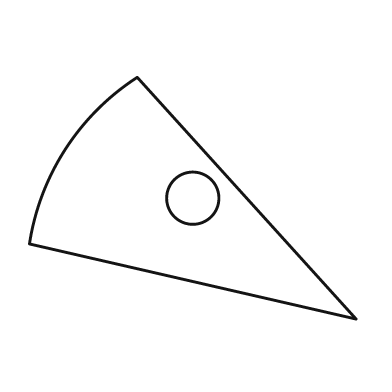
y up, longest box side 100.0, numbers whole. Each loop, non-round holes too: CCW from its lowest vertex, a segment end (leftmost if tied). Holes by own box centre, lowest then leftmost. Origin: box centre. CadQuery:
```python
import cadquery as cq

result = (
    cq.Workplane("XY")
    .moveTo(50.0, -37.0)
    .lineTo(-17.0, 37.0)
    .threePointArc((-39.0, 15.0), (-50.0, -14.0))
    .close()
    .moveTo(0.0, 0.0)
    .circle(8.0)
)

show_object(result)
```